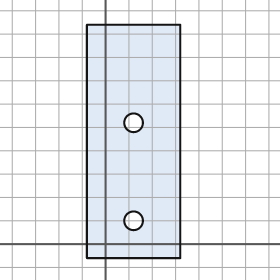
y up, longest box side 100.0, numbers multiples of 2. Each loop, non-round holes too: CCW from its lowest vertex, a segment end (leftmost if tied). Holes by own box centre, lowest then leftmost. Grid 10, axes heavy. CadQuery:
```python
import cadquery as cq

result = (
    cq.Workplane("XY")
    .moveTo(-8.0, -6.0)
    .lineTo(32.0, -6.0)
    .lineTo(32.0, 94.0)
    .lineTo(-8.0, 94.0)
    .close()
    .moveTo(12.0, 10.0)
    .circle(4.0)
    .moveTo(12.0, 52.0)
    .circle(4.0)
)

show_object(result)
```